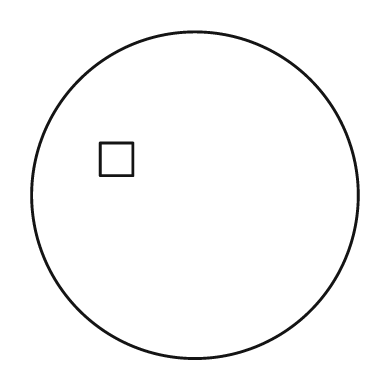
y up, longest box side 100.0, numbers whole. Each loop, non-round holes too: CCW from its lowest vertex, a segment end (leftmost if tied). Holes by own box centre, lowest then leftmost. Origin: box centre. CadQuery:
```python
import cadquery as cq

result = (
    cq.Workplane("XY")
    .moveTo(0.0, 0.0)
    .circle(50.0)
    .moveTo(-29.0, 6.0)
    .lineTo(-19.0, 6.0)
    .lineTo(-19.0, 16.0)
    .lineTo(-29.0, 16.0)
    .close()
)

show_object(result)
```